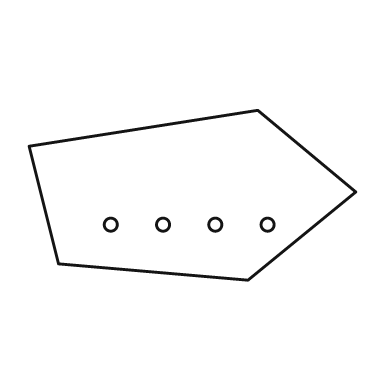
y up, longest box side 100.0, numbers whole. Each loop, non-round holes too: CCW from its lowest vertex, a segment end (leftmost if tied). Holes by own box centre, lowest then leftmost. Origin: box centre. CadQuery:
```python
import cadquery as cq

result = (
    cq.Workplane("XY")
    .moveTo(17.0, -26.0)
    .lineTo(50.0, 1.0)
    .lineTo(20.0, 26.0)
    .lineTo(-50.0, 15.0)
    .lineTo(-41.0, -21.0)
    .close()
    .moveTo(-25.0, -9.0)
    .circle(2.0)
    .moveTo(-9.0, -9.0)
    .circle(2.0)
    .moveTo(7.0, -9.0)
    .circle(2.0)
    .moveTo(23.0, -9.0)
    .circle(2.0)
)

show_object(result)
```